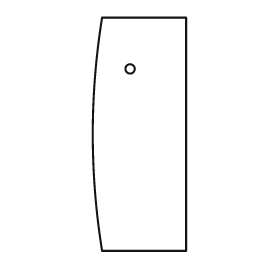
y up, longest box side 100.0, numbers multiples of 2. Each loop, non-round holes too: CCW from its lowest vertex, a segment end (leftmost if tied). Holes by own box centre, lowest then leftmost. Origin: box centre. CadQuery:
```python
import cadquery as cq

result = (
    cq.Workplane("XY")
    .moveTo(-16.0, -50.0)
    .lineTo(20.0, -50.0)
    .lineTo(20.0, 50.0)
    .lineTo(-16.0, 50.0)
    .threePointArc((-20.0, 0.0), (-16.0, -50.0))
    .close()
    .moveTo(-4.0, 28.0)
    .circle(2.0)
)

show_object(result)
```